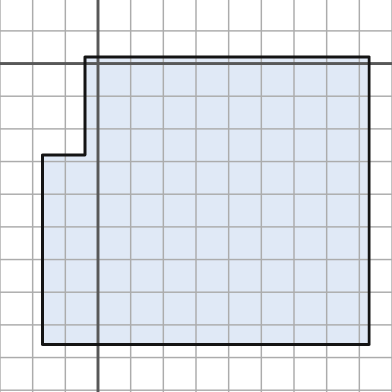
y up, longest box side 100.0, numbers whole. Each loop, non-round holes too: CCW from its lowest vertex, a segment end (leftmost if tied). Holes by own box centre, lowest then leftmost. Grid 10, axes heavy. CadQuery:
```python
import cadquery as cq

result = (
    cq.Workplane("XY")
    .moveTo(-17.0, -86.0)
    .lineTo(83.0, -86.0)
    .lineTo(83.0, 2.0)
    .lineTo(-4.0, 2.0)
    .lineTo(-4.0, -28.0)
    .lineTo(-17.0, -28.0)
    .close()
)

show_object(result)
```